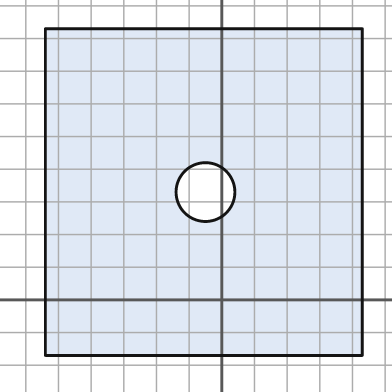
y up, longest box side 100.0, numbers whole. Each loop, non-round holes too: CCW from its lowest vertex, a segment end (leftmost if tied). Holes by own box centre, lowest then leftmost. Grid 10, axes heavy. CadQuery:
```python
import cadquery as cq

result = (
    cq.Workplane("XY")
    .moveTo(-54.0, -17.0)
    .lineTo(43.0, -17.0)
    .lineTo(43.0, 83.0)
    .lineTo(-54.0, 83.0)
    .close()
    .moveTo(-5.0, 33.0)
    .circle(9.0)
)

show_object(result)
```